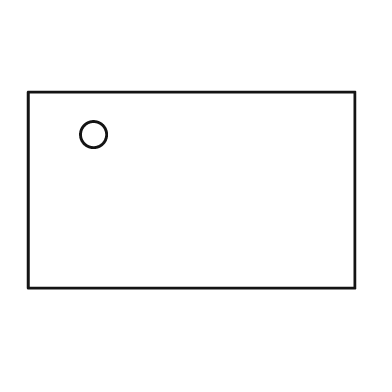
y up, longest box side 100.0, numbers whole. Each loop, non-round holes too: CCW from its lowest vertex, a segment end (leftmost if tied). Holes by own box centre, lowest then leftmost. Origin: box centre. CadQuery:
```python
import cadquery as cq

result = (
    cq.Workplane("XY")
    .moveTo(-50.0, -30.0)
    .lineTo(50.0, -30.0)
    .lineTo(50.0, 30.0)
    .lineTo(-50.0, 30.0)
    .close()
    .moveTo(-30.0, 17.0)
    .circle(4.0)
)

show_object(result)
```